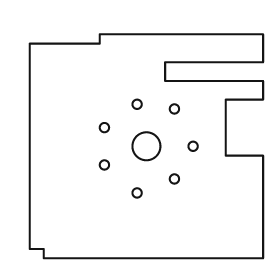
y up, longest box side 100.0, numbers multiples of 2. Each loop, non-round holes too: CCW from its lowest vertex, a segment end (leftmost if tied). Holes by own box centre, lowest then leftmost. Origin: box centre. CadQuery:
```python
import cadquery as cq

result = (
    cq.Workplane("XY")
    .moveTo(-44.0, -48.0)
    .lineTo(50.0, -48.0)
    .lineTo(50.0, -4.0)
    .lineTo(34.0, -4.0)
    .lineTo(34.0, 20.0)
    .lineTo(50.0, 20.0)
    .lineTo(50.0, 28.0)
    .lineTo(8.0, 28.0)
    .lineTo(8.0, 36.0)
    .lineTo(50.0, 36.0)
    .lineTo(50.0, 48.0)
    .lineTo(-20.0, 48.0)
    .lineTo(-20.0, 44.0)
    .lineTo(-50.0, 44.0)
    .lineTo(-50.0, -44.0)
    .lineTo(-44.0, -44.0)
    .close()
    .moveTo(-4.0, -20.0)
    .circle(2.0)
    .moveTo(12.0, -14.0)
    .circle(2.0)
    .moveTo(-18.0, -8.0)
    .circle(2.0)
    .moveTo(0.0, 0.0)
    .circle(6.0)
    .moveTo(20.0, 0.0)
    .circle(2.0)
    .moveTo(-18.0, 8.0)
    .circle(2.0)
    .moveTo(12.0, 16.0)
    .circle(2.0)
    .moveTo(-4.0, 18.0)
    .circle(2.0)
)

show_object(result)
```